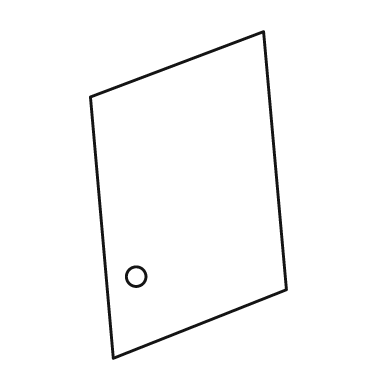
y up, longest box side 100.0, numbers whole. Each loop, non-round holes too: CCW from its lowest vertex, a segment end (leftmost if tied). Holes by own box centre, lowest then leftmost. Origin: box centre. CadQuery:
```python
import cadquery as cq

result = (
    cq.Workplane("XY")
    .moveTo(-23.0, -50.0)
    .lineTo(30.0, -29.0)
    .lineTo(23.0, 50.0)
    .lineTo(-30.0, 30.0)
    .close()
    .moveTo(-16.0, -25.0)
    .circle(3.0)
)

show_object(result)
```